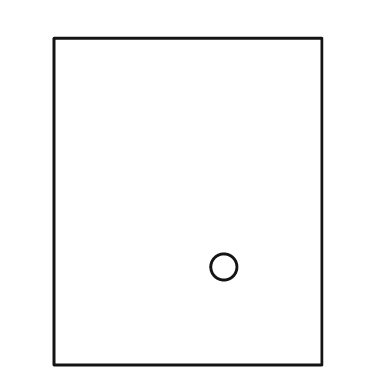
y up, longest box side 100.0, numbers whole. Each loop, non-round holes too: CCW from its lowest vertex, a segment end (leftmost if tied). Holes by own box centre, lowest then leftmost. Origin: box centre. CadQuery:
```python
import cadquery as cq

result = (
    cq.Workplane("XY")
    .moveTo(-41.0, -50.0)
    .lineTo(41.0, -50.0)
    .lineTo(41.0, 50.0)
    .lineTo(-41.0, 50.0)
    .close()
    .moveTo(11.0, -20.0)
    .circle(4.0)
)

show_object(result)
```